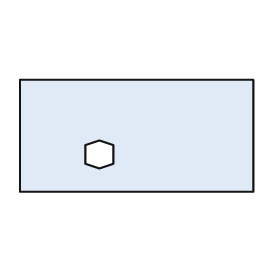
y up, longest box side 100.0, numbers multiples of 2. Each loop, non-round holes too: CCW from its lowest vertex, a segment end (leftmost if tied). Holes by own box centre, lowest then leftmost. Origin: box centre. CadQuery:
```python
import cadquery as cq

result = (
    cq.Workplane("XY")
    .moveTo(-50.0, -24.0)
    .lineTo(50.0, -24.0)
    .lineTo(50.0, 24.0)
    .lineTo(-50.0, 24.0)
    .close()
    .moveTo(-16.0, -14.0)
    .lineTo(-10.0, -12.0)
    .lineTo(-10.0, -4.0)
    .lineTo(-16.0, -2.0)
    .lineTo(-22.0, -4.0)
    .lineTo(-22.0, -12.0)
    .close()
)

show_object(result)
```